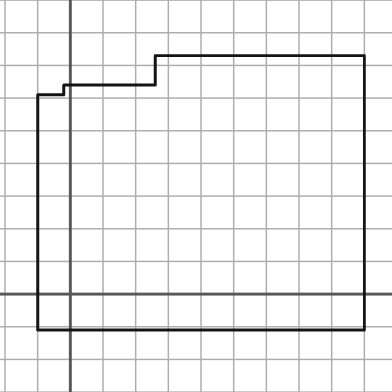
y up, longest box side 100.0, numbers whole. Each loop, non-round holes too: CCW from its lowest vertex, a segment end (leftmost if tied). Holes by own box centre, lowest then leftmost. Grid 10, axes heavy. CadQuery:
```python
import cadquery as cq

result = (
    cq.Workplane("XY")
    .moveTo(-10.0, -11.0)
    .lineTo(90.0, -11.0)
    .lineTo(90.0, 73.0)
    .lineTo(26.0, 73.0)
    .lineTo(26.0, 64.0)
    .lineTo(-2.0, 64.0)
    .lineTo(-2.0, 61.0)
    .lineTo(-10.0, 61.0)
    .close()
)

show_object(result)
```